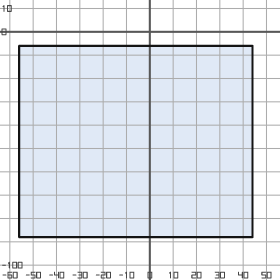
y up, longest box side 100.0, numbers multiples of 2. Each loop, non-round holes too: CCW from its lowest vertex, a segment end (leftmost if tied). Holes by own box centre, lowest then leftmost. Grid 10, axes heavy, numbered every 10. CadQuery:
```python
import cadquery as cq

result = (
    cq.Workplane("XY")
    .moveTo(-56.0, -88.0)
    .lineTo(44.0, -88.0)
    .lineTo(44.0, -6.0)
    .lineTo(-56.0, -6.0)
    .close()
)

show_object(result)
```